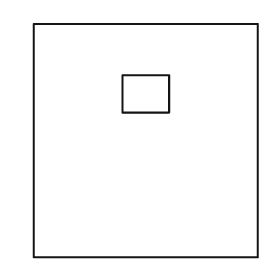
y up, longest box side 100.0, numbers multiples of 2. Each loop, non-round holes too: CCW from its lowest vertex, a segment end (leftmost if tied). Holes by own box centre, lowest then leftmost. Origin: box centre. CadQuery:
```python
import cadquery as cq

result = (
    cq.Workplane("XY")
    .moveTo(-48.0, -50.0)
    .lineTo(48.0, -50.0)
    .lineTo(48.0, 50.0)
    .lineTo(-48.0, 50.0)
    .close()
    .moveTo(-10.0, 12.0)
    .lineTo(10.0, 12.0)
    .lineTo(10.0, 28.0)
    .lineTo(-10.0, 28.0)
    .close()
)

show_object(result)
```